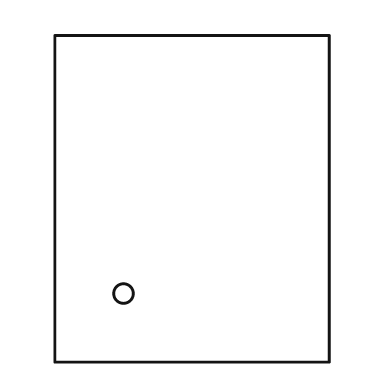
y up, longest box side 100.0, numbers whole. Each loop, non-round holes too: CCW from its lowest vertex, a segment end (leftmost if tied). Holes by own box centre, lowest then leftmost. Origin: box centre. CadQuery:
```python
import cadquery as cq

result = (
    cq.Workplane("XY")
    .moveTo(-42.0, -50.0)
    .lineTo(42.0, -50.0)
    .lineTo(42.0, 50.0)
    .lineTo(-42.0, 50.0)
    .close()
    .moveTo(-21.0, -29.0)
    .circle(3.0)
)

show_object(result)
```